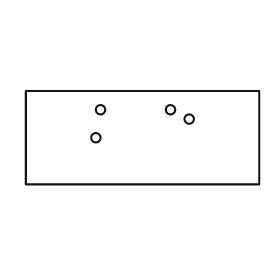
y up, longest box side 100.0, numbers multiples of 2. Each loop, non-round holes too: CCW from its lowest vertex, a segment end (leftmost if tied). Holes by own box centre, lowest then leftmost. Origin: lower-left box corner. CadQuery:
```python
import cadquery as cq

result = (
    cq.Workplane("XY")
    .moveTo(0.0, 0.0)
    .lineTo(100.0, 0.0)
    .lineTo(100.0, 40.0)
    .lineTo(0.0, 40.0)
    .close()
    .moveTo(30.0, 20.0)
    .circle(2.0)
    .moveTo(70.0, 28.0)
    .circle(2.0)
    .moveTo(32.0, 32.0)
    .circle(2.0)
    .moveTo(62.0, 32.0)
    .circle(2.0)
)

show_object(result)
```